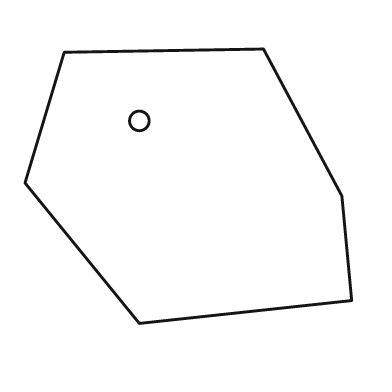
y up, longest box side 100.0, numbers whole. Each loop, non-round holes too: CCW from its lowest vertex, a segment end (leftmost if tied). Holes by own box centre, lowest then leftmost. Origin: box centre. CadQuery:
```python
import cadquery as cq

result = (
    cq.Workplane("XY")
    .moveTo(-15.0, -42.0)
    .lineTo(50.0, -35.0)
    .lineTo(47.0, -3.0)
    .lineTo(23.0, 42.0)
    .lineTo(-38.0, 41.0)
    .lineTo(-50.0, 1.0)
    .close()
    .moveTo(-15.0, 20.0)
    .circle(3.0)
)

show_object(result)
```